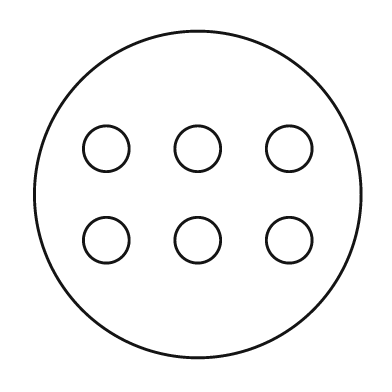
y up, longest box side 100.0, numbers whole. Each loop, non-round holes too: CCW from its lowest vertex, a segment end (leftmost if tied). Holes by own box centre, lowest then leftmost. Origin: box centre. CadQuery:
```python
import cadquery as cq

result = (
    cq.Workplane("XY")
    .moveTo(0.0, 0.0)
    .circle(50.0)
    .moveTo(-28.0, -14.0)
    .circle(7.0)
    .moveTo(0.0, -14.0)
    .circle(7.0)
    .moveTo(28.0, -14.0)
    .circle(7.0)
    .moveTo(-28.0, 14.0)
    .circle(7.0)
    .moveTo(0.0, 14.0)
    .circle(7.0)
    .moveTo(28.0, 14.0)
    .circle(7.0)
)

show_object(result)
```